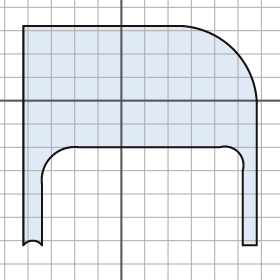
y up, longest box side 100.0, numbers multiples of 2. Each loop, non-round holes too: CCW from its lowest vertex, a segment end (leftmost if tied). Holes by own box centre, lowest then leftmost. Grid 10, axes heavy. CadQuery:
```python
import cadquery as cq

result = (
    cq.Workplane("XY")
    .moveTo(-42.0, -62.0)
    .threePointArc((-38.0, -60.0), (-34.0, -62.0))
    .lineTo(-34.0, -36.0)
    .threePointArc((-30.0, -24.0), (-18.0, -20.0))
    .lineTo(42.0, -20.0)
    .threePointArc((50.0, -22.0), (52.0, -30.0))
    .lineTo(52.0, -62.0)
    .lineTo(58.0, -62.0)
    .lineTo(58.0, 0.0)
    .threePointArc((48.0, 22.0), (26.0, 32.0))
    .lineTo(-42.0, 32.0)
    .close()
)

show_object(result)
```